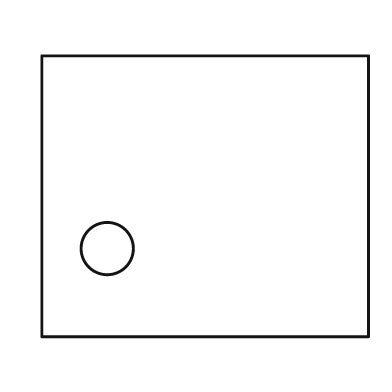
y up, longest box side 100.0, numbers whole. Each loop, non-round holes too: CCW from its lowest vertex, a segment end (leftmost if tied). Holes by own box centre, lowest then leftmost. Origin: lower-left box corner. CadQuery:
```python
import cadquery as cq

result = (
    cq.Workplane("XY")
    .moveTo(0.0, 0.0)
    .lineTo(100.0, 0.0)
    .lineTo(100.0, 86.0)
    .lineTo(0.0, 86.0)
    .close()
    .moveTo(20.0, 27.0)
    .circle(8.0)
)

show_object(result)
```